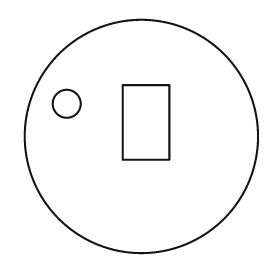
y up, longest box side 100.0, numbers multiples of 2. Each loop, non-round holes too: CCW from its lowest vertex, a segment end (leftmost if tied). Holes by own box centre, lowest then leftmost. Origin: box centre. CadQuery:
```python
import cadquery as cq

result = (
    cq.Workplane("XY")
    .moveTo(0.0, 0.0)
    .circle(50.0)
    .moveTo(-8.0, -10.0)
    .lineTo(12.0, -10.0)
    .lineTo(12.0, 22.0)
    .lineTo(-8.0, 22.0)
    .close()
    .moveTo(-32.0, 14.0)
    .circle(6.0)
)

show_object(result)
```